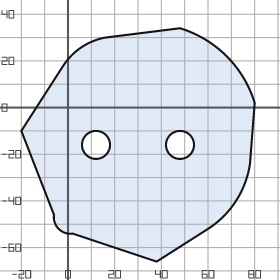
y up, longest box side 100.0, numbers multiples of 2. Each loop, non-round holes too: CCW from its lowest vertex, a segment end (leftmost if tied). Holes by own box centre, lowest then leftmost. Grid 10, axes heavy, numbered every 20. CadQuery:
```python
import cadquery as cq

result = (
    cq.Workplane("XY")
    .moveTo(38.0, -66.0)
    .lineTo(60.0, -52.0)
    .threePointArc((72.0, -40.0), (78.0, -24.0))
    .lineTo(80.0, 2.0)
    .threePointArc((68.0, 22.0), (48.0, 34.0))
    .lineTo(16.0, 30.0)
    .threePointArc((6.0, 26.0), (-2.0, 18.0))
    .lineTo(-20.0, -10.0)
    .lineTo(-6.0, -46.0)
    .threePointArc((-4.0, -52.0), (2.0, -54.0))
    .close()
    .moveTo(12.0, -16.0)
    .circle(6.0)
    .moveTo(48.0, -16.0)
    .circle(6.0)
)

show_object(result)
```